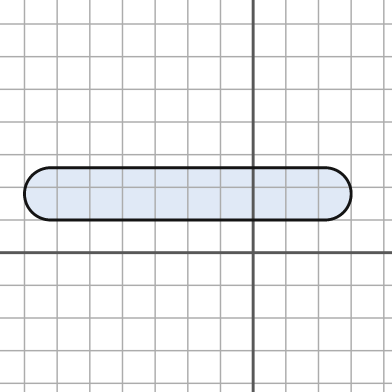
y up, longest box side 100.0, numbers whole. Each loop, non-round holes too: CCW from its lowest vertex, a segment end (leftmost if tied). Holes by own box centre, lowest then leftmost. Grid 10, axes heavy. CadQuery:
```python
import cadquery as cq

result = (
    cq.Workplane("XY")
    .moveTo(-62.0, 10.0)
    .lineTo(22.0, 10.0)
    .threePointArc((30.0, 18.0), (22.0, 26.0))
    .lineTo(-62.0, 26.0)
    .threePointArc((-70.0, 18.0), (-62.0, 10.0))
    .close()
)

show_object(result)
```